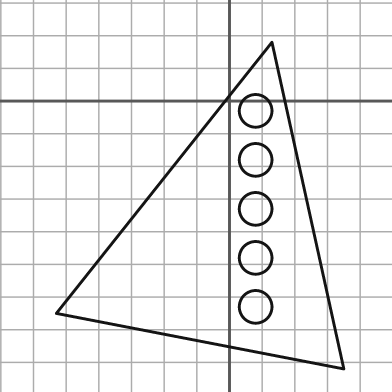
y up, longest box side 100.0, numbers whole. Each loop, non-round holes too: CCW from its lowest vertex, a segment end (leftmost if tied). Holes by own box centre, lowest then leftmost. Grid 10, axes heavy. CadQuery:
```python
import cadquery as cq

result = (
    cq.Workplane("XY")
    .moveTo(35.0, -82.0)
    .lineTo(13.0, 18.0)
    .lineTo(-53.0, -65.0)
    .close()
    .moveTo(8.0, -63.0)
    .circle(5.0)
    .moveTo(8.0, -48.0)
    .circle(5.0)
    .moveTo(8.0, -33.0)
    .circle(5.0)
    .moveTo(8.0, -18.0)
    .circle(5.0)
    .moveTo(8.0, -3.0)
    .circle(5.0)
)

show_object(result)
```